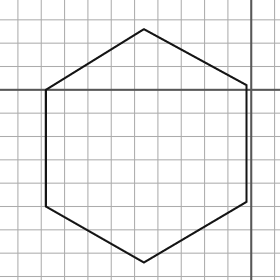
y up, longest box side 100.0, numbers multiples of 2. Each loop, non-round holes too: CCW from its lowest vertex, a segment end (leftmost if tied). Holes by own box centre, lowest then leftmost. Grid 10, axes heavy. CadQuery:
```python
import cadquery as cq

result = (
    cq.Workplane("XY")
    .moveTo(-46.0, -74.0)
    .lineTo(-2.0, -48.0)
    .lineTo(-2.0, 2.0)
    .lineTo(-46.0, 26.0)
    .lineTo(-88.0, 0.0)
    .lineTo(-88.0, -50.0)
    .close()
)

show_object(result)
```